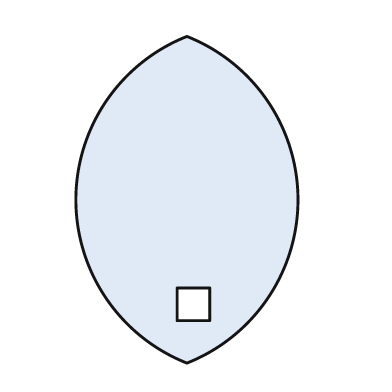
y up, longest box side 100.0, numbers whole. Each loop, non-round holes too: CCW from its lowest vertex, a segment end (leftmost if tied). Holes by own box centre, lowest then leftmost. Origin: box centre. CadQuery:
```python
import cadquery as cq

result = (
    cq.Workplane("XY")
    .moveTo(0.0, -50.0)
    .threePointArc((34.0, 0.0), (0.0, 50.0))
    .threePointArc((-34.0, 0.0), (0.0, -50.0))
    .close()
    .moveTo(-3.0, -37.0)
    .lineTo(7.0, -37.0)
    .lineTo(7.0, -27.0)
    .lineTo(-3.0, -27.0)
    .close()
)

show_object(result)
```